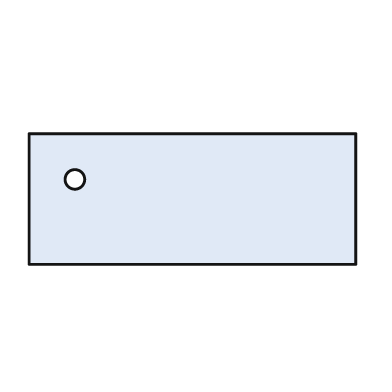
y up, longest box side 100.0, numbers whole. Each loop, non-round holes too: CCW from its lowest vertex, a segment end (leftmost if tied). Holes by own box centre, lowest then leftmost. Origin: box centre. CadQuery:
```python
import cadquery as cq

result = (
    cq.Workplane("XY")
    .moveTo(-50.0, -20.0)
    .lineTo(50.0, -20.0)
    .lineTo(50.0, 20.0)
    .lineTo(-50.0, 20.0)
    .close()
    .moveTo(-36.0, 6.0)
    .circle(3.0)
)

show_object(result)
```